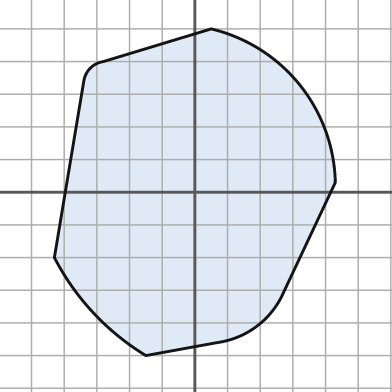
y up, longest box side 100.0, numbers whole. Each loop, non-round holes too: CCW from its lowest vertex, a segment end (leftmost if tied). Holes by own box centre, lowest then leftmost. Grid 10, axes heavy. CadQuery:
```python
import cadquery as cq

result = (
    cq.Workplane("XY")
    .moveTo(-15.0, -50.0)
    .lineTo(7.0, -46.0)
    .threePointArc((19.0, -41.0), (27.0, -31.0))
    .lineTo(43.0, 3.0)
    .threePointArc((32.0, 33.0), (5.0, 50.0))
    .lineTo(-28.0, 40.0)
    .threePointArc((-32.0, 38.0), (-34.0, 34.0))
    .lineTo(-43.0, -20.0)
    .threePointArc((-31.0, -37.0), (-15.0, -50.0))
    .close()
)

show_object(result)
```